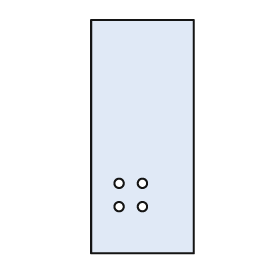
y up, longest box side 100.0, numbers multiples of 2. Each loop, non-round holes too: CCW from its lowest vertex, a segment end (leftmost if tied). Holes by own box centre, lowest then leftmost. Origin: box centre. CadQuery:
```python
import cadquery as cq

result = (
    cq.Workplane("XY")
    .moveTo(-22.0, -50.0)
    .lineTo(22.0, -50.0)
    .lineTo(22.0, 50.0)
    .lineTo(-22.0, 50.0)
    .close()
    .moveTo(-10.0, -30.0)
    .circle(2.0)
    .moveTo(0.0, -30.0)
    .circle(2.0)
    .moveTo(-10.0, -20.0)
    .circle(2.0)
    .moveTo(0.0, -20.0)
    .circle(2.0)
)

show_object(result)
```